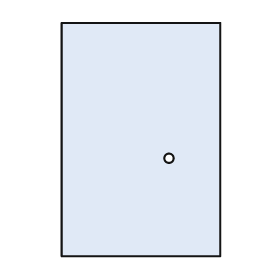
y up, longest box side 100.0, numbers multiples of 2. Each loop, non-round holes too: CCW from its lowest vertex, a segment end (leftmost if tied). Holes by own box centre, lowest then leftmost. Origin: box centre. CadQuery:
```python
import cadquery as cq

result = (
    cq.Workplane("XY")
    .moveTo(-34.0, -50.0)
    .lineTo(34.0, -50.0)
    .lineTo(34.0, 50.0)
    .lineTo(-34.0, 50.0)
    .close()
    .moveTo(12.0, -8.0)
    .circle(2.0)
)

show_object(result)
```